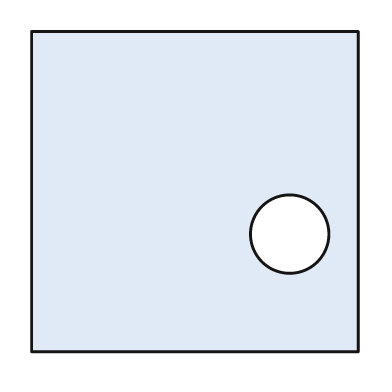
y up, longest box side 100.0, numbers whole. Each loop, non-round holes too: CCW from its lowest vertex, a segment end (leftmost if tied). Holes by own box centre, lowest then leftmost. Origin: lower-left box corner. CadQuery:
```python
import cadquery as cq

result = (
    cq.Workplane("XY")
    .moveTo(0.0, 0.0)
    .lineTo(100.0, 0.0)
    .lineTo(100.0, 98.0)
    .lineTo(0.0, 98.0)
    .close()
    .moveTo(79.0, 36.0)
    .circle(12.0)
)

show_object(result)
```